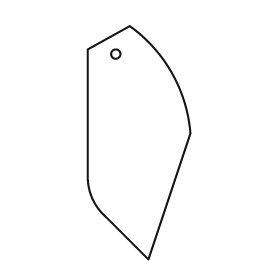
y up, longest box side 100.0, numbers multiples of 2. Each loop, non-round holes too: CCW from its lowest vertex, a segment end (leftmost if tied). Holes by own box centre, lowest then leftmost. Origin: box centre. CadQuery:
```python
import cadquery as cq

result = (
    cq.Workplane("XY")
    .moveTo(4.0, -50.0)
    .lineTo(22.0, 4.0)
    .threePointArc((14.0, 30.0), (-4.0, 50.0))
    .lineTo(-22.0, 40.0)
    .lineTo(-22.0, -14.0)
    .threePointArc((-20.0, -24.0), (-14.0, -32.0))
    .close()
    .moveTo(-10.0, 38.0)
    .circle(2.0)
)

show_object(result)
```